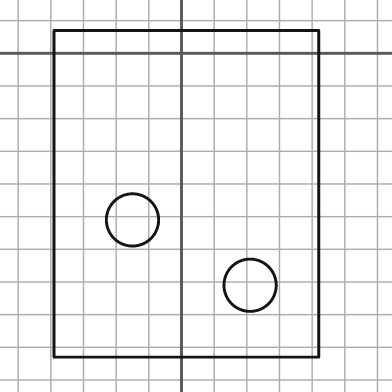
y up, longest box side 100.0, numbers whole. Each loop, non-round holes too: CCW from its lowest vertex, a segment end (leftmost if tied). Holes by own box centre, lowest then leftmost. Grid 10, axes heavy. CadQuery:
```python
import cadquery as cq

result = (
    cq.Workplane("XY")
    .moveTo(-39.0, -93.0)
    .lineTo(42.0, -93.0)
    .lineTo(42.0, 7.0)
    .lineTo(-39.0, 7.0)
    .close()
    .moveTo(21.0, -71.0)
    .circle(8.0)
    .moveTo(-15.0, -51.0)
    .circle(8.0)
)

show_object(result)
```